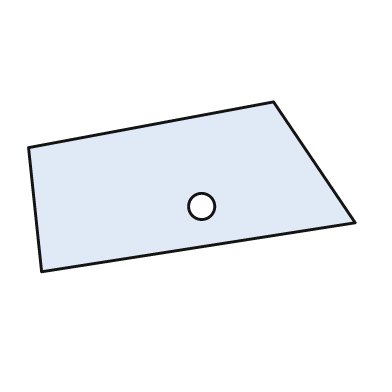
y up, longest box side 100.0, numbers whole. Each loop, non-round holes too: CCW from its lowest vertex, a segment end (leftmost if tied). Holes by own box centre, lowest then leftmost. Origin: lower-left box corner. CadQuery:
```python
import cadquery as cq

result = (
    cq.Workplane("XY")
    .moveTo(4.0, 0.0)
    .lineTo(100.0, 15.0)
    .lineTo(75.0, 52.0)
    .lineTo(0.0, 38.0)
    .close()
    .moveTo(53.0, 20.0)
    .circle(4.0)
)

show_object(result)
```